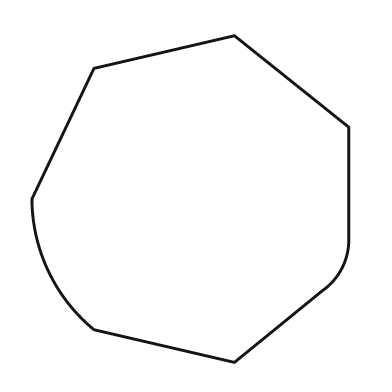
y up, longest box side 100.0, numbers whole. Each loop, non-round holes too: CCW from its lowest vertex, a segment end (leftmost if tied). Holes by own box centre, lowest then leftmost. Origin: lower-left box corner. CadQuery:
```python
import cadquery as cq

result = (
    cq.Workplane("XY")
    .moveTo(62.0, 0.0)
    .lineTo(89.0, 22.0)
    .threePointArc((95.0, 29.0), (97.0, 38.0))
    .lineTo(97.0, 72.0)
    .lineTo(62.0, 100.0)
    .lineTo(19.0, 90.0)
    .lineTo(0.0, 50.0)
    .threePointArc((5.0, 28.0), (19.0, 10.0))
    .close()
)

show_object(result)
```